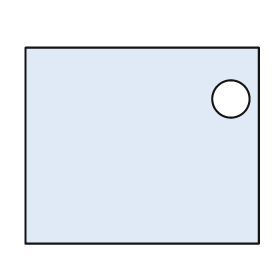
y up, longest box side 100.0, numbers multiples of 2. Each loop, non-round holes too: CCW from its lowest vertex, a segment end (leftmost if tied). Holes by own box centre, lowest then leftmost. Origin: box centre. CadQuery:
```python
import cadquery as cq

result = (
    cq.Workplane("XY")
    .moveTo(-50.0, -42.0)
    .lineTo(50.0, -42.0)
    .lineTo(50.0, 42.0)
    .lineTo(-50.0, 42.0)
    .close()
    .moveTo(38.0, 20.0)
    .circle(8.0)
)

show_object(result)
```